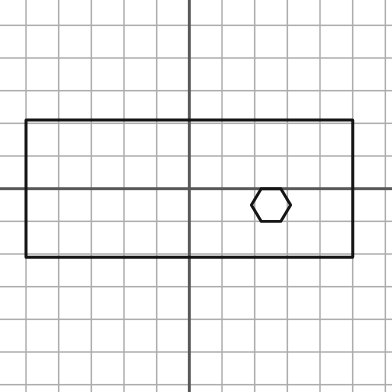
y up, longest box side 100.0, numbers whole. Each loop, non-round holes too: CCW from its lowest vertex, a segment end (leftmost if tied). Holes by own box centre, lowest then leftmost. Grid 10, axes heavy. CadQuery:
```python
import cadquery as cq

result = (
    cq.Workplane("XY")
    .moveTo(-50.0, -21.0)
    .lineTo(50.0, -21.0)
    .lineTo(50.0, 21.0)
    .lineTo(-50.0, 21.0)
    .close()
    .moveTo(22.0, -10.0)
    .lineTo(28.0, -10.0)
    .lineTo(31.0, -5.0)
    .lineTo(28.0, 0.0)
    .lineTo(22.0, 0.0)
    .lineTo(19.0, -5.0)
    .close()
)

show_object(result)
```